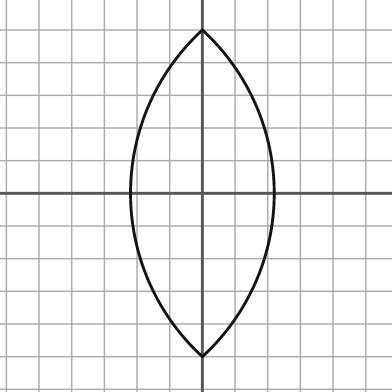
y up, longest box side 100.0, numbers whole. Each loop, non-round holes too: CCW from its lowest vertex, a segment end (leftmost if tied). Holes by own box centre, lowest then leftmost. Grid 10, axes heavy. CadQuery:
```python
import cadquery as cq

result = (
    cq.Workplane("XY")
    .moveTo(0.0, -50.0)
    .threePointArc((22.0, 0.0), (0.0, 50.0))
    .threePointArc((-22.0, 0.0), (0.0, -50.0))
    .close()
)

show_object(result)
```